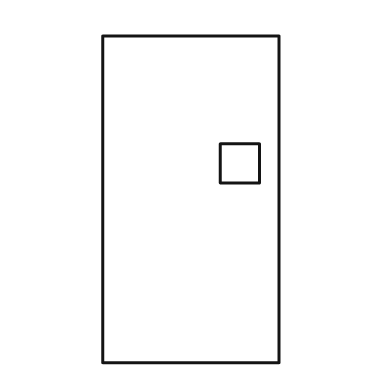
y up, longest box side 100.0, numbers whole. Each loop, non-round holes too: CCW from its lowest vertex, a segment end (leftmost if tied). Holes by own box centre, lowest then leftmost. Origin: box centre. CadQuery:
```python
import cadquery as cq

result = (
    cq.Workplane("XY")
    .moveTo(-27.0, -50.0)
    .lineTo(27.0, -50.0)
    .lineTo(27.0, 50.0)
    .lineTo(-27.0, 50.0)
    .close()
    .moveTo(9.0, 5.0)
    .lineTo(21.0, 5.0)
    .lineTo(21.0, 17.0)
    .lineTo(9.0, 17.0)
    .close()
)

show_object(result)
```